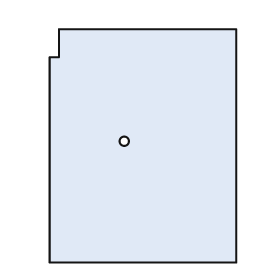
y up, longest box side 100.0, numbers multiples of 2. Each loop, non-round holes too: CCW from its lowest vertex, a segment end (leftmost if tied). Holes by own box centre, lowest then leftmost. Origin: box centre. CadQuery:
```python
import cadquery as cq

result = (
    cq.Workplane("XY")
    .moveTo(-40.0, -50.0)
    .lineTo(40.0, -50.0)
    .lineTo(40.0, 50.0)
    .lineTo(-36.0, 50.0)
    .lineTo(-36.0, 38.0)
    .lineTo(-40.0, 38.0)
    .close()
    .moveTo(-8.0, 2.0)
    .circle(2.0)
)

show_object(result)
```